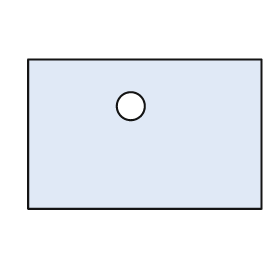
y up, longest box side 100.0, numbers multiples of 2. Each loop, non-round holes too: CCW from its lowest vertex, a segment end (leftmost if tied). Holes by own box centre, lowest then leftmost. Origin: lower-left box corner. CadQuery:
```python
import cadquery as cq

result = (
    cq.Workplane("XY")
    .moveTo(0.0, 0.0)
    .lineTo(100.0, 0.0)
    .lineTo(100.0, 64.0)
    .lineTo(0.0, 64.0)
    .close()
    .moveTo(44.0, 44.0)
    .circle(6.0)
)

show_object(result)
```